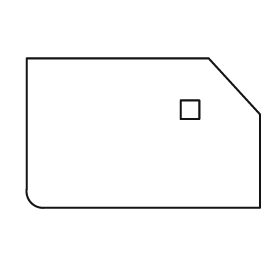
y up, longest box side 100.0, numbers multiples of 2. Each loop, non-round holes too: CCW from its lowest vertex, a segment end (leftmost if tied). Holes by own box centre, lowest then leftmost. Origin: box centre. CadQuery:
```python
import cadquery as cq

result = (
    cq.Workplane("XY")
    .moveTo(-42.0, -32.0)
    .lineTo(50.0, -32.0)
    .lineTo(50.0, 8.0)
    .lineTo(28.0, 32.0)
    .lineTo(-50.0, 32.0)
    .lineTo(-50.0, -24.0)
    .threePointArc((-48.0, -30.0), (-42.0, -32.0))
    .close()
    .moveTo(16.0, 6.0)
    .lineTo(24.0, 6.0)
    .lineTo(24.0, 14.0)
    .lineTo(16.0, 14.0)
    .close()
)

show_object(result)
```